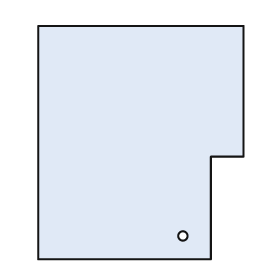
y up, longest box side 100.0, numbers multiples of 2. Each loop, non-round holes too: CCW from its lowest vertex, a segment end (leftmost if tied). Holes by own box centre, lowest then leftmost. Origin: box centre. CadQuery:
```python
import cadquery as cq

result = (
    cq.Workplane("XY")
    .moveTo(-44.0, -50.0)
    .lineTo(30.0, -50.0)
    .lineTo(30.0, -6.0)
    .lineTo(44.0, -6.0)
    .lineTo(44.0, 50.0)
    .lineTo(-44.0, 50.0)
    .close()
    .moveTo(18.0, -40.0)
    .circle(2.0)
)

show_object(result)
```